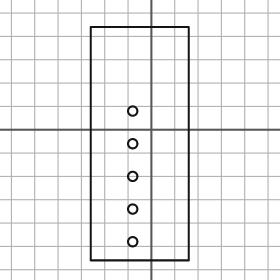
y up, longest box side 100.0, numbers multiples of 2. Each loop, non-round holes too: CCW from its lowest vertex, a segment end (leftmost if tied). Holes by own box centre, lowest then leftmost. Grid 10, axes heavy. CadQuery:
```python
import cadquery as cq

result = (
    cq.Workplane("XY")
    .moveTo(-26.0, -56.0)
    .lineTo(16.0, -56.0)
    .lineTo(16.0, 44.0)
    .lineTo(-26.0, 44.0)
    .close()
    .moveTo(-8.0, -48.0)
    .circle(2.0)
    .moveTo(-8.0, -34.0)
    .circle(2.0)
    .moveTo(-8.0, -20.0)
    .circle(2.0)
    .moveTo(-8.0, -6.0)
    .circle(2.0)
    .moveTo(-8.0, 8.0)
    .circle(2.0)
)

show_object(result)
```